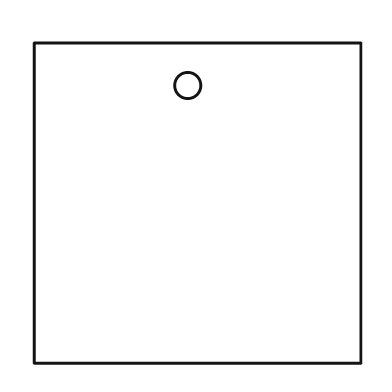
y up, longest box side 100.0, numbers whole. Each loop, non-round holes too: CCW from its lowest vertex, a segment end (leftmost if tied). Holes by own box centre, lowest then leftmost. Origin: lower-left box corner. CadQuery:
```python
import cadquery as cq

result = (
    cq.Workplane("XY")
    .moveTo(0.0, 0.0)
    .lineTo(100.0, 0.0)
    .lineTo(100.0, 98.0)
    .lineTo(0.0, 98.0)
    .close()
    .moveTo(47.0, 85.0)
    .circle(4.0)
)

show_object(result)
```